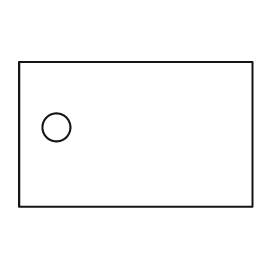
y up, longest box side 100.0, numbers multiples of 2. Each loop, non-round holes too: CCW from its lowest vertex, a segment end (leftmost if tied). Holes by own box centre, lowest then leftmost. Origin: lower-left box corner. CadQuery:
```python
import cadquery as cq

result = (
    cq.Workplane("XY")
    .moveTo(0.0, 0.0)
    .lineTo(100.0, 0.0)
    .lineTo(100.0, 62.0)
    .lineTo(0.0, 62.0)
    .close()
    .moveTo(16.0, 34.0)
    .circle(6.0)
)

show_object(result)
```